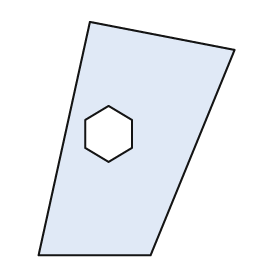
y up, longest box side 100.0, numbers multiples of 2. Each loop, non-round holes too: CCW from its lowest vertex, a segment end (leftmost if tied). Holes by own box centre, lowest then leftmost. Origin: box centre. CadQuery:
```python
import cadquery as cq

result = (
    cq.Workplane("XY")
    .moveTo(-42.0, -50.0)
    .lineTo(6.0, -50.0)
    .lineTo(42.0, 38.0)
    .lineTo(-20.0, 50.0)
    .close()
    .moveTo(-12.0, -10.0)
    .lineTo(-2.0, -4.0)
    .lineTo(-2.0, 8.0)
    .lineTo(-12.0, 14.0)
    .lineTo(-22.0, 8.0)
    .lineTo(-22.0, -4.0)
    .close()
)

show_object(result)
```